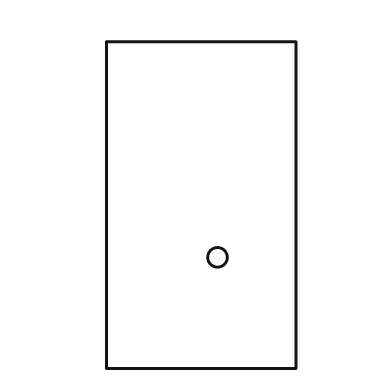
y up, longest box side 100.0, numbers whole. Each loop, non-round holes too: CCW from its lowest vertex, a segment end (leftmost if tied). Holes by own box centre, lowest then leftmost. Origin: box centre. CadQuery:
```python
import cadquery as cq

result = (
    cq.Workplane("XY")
    .moveTo(-29.0, -50.0)
    .lineTo(29.0, -50.0)
    .lineTo(29.0, 50.0)
    .lineTo(-29.0, 50.0)
    .close()
    .moveTo(5.0, -16.0)
    .circle(3.0)
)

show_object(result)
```